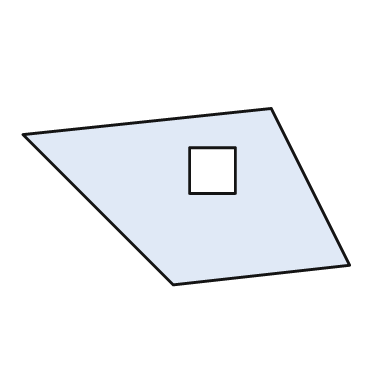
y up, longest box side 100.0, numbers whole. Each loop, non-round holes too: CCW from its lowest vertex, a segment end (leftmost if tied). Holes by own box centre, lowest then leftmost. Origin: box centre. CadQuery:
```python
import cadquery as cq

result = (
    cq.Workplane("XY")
    .moveTo(-4.0, -27.0)
    .lineTo(50.0, -21.0)
    .lineTo(26.0, 27.0)
    .lineTo(-50.0, 19.0)
    .close()
    .moveTo(1.0, 1.0)
    .lineTo(15.0, 1.0)
    .lineTo(15.0, 15.0)
    .lineTo(1.0, 15.0)
    .close()
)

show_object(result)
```